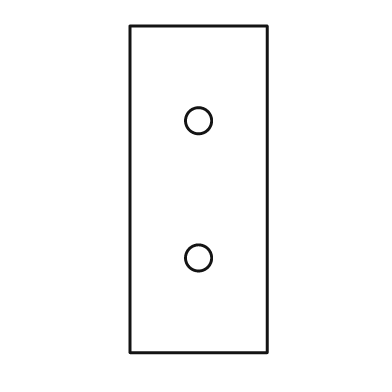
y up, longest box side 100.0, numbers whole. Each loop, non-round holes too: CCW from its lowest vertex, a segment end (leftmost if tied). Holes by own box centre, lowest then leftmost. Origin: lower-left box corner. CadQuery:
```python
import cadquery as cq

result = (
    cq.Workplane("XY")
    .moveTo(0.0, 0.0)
    .lineTo(42.0, 0.0)
    .lineTo(42.0, 100.0)
    .lineTo(0.0, 100.0)
    .close()
    .moveTo(21.0, 29.0)
    .circle(4.0)
    .moveTo(21.0, 71.0)
    .circle(4.0)
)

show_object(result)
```